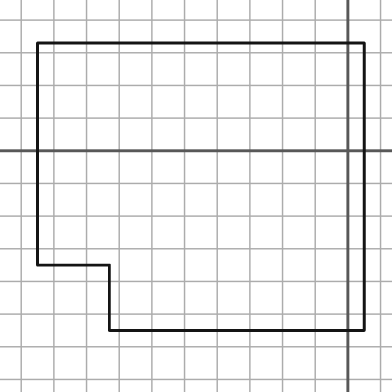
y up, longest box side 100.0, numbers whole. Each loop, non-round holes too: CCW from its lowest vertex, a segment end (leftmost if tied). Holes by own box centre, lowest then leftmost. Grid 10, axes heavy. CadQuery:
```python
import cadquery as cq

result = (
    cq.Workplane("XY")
    .moveTo(-73.0, -55.0)
    .lineTo(5.0, -55.0)
    .lineTo(5.0, 33.0)
    .lineTo(-95.0, 33.0)
    .lineTo(-95.0, -35.0)
    .lineTo(-73.0, -35.0)
    .close()
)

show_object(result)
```